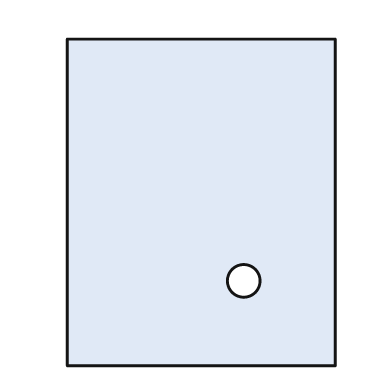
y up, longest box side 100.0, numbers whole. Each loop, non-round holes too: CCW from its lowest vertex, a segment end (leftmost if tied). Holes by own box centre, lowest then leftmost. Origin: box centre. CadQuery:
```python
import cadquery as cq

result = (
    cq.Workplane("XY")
    .moveTo(-41.0, -50.0)
    .lineTo(41.0, -50.0)
    .lineTo(41.0, 50.0)
    .lineTo(-41.0, 50.0)
    .close()
    .moveTo(13.0, -24.0)
    .circle(5.0)
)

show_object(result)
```